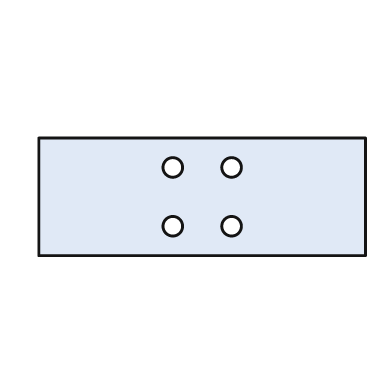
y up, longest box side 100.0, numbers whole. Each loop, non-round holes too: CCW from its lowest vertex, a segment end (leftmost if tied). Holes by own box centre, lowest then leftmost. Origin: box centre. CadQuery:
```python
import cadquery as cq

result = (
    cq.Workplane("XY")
    .moveTo(-50.0, -18.0)
    .lineTo(50.0, -18.0)
    .lineTo(50.0, 18.0)
    .lineTo(-50.0, 18.0)
    .close()
    .moveTo(-9.0, -9.0)
    .circle(3.0)
    .moveTo(9.0, -9.0)
    .circle(3.0)
    .moveTo(-9.0, 9.0)
    .circle(3.0)
    .moveTo(9.0, 9.0)
    .circle(3.0)
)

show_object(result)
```